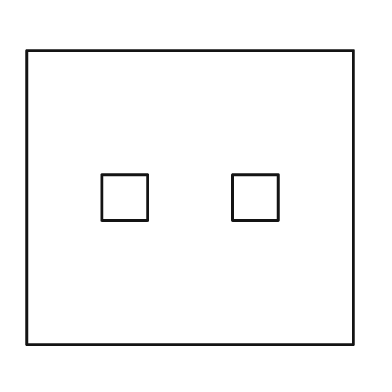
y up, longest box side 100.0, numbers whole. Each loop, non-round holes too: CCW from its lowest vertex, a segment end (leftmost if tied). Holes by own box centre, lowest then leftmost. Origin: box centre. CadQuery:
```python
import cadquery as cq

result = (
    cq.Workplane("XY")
    .moveTo(-50.0, -45.0)
    .lineTo(50.0, -45.0)
    .lineTo(50.0, 45.0)
    .lineTo(-50.0, 45.0)
    .close()
    .moveTo(-27.0, -7.0)
    .lineTo(-13.0, -7.0)
    .lineTo(-13.0, 7.0)
    .lineTo(-27.0, 7.0)
    .close()
    .moveTo(13.0, -7.0)
    .lineTo(27.0, -7.0)
    .lineTo(27.0, 7.0)
    .lineTo(13.0, 7.0)
    .close()
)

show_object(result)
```